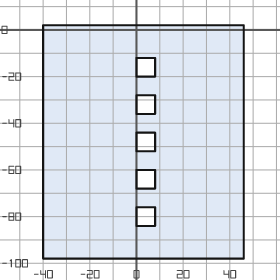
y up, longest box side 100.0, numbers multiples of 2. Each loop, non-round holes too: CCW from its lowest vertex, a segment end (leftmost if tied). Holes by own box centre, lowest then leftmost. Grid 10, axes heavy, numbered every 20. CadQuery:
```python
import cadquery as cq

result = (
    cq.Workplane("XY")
    .moveTo(-40.0, -98.0)
    .lineTo(46.0, -98.0)
    .lineTo(46.0, 2.0)
    .lineTo(-40.0, 2.0)
    .close()
    .moveTo(0.0, -84.0)
    .lineTo(8.0, -84.0)
    .lineTo(8.0, -76.0)
    .lineTo(0.0, -76.0)
    .close()
    .moveTo(0.0, -68.0)
    .lineTo(8.0, -68.0)
    .lineTo(8.0, -60.0)
    .lineTo(0.0, -60.0)
    .close()
    .moveTo(0.0, -52.0)
    .lineTo(8.0, -52.0)
    .lineTo(8.0, -44.0)
    .lineTo(0.0, -44.0)
    .close()
    .moveTo(0.0, -36.0)
    .lineTo(8.0, -36.0)
    .lineTo(8.0, -28.0)
    .lineTo(0.0, -28.0)
    .close()
    .moveTo(0.0, -20.0)
    .lineTo(8.0, -20.0)
    .lineTo(8.0, -12.0)
    .lineTo(0.0, -12.0)
    .close()
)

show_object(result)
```